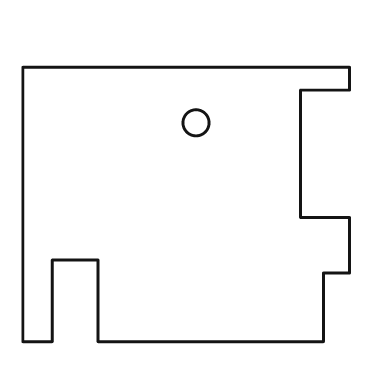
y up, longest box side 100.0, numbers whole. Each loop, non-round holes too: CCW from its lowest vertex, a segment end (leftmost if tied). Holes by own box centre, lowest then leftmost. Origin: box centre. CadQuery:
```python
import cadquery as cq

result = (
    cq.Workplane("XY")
    .moveTo(-50.0, -42.0)
    .lineTo(-41.0, -42.0)
    .lineTo(-41.0, -17.0)
    .lineTo(-27.0, -17.0)
    .lineTo(-27.0, -42.0)
    .lineTo(42.0, -42.0)
    .lineTo(42.0, -21.0)
    .lineTo(50.0, -21.0)
    .lineTo(50.0, -4.0)
    .lineTo(35.0, -4.0)
    .lineTo(35.0, 35.0)
    .lineTo(50.0, 35.0)
    .lineTo(50.0, 42.0)
    .lineTo(-50.0, 42.0)
    .close()
    .moveTo(3.0, 25.0)
    .circle(4.0)
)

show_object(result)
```